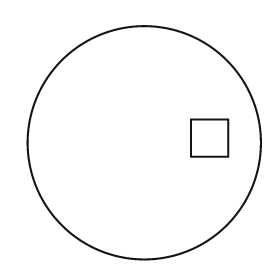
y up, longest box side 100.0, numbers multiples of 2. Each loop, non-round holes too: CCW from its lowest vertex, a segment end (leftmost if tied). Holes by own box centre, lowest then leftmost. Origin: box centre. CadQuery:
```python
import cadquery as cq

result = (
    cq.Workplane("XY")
    .moveTo(0.0, 0.0)
    .circle(50.0)
    .moveTo(20.0, -6.0)
    .lineTo(36.0, -6.0)
    .lineTo(36.0, 10.0)
    .lineTo(20.0, 10.0)
    .close()
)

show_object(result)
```